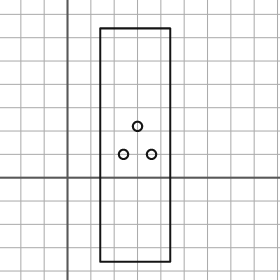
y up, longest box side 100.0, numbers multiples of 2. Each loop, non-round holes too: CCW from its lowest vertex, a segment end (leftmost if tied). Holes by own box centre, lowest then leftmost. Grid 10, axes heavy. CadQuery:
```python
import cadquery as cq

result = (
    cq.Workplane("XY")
    .moveTo(14.0, -36.0)
    .lineTo(44.0, -36.0)
    .lineTo(44.0, 64.0)
    .lineTo(14.0, 64.0)
    .close()
    .moveTo(24.0, 10.0)
    .circle(2.0)
    .moveTo(36.0, 10.0)
    .circle(2.0)
    .moveTo(30.0, 22.0)
    .circle(2.0)
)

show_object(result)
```